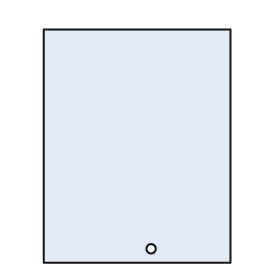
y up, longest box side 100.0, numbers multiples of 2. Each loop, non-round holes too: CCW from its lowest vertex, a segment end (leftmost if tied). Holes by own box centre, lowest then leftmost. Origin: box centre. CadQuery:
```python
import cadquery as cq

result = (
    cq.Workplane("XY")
    .moveTo(-40.0, -50.0)
    .lineTo(40.0, -50.0)
    .lineTo(40.0, 50.0)
    .lineTo(-40.0, 50.0)
    .close()
    .moveTo(6.0, -44.0)
    .circle(2.0)
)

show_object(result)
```